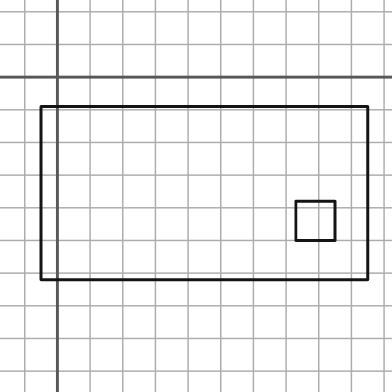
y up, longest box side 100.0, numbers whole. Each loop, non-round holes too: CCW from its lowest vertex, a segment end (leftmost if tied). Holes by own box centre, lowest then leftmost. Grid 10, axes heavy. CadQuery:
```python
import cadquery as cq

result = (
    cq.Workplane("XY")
    .moveTo(-5.0, -62.0)
    .lineTo(95.0, -62.0)
    .lineTo(95.0, -9.0)
    .lineTo(-5.0, -9.0)
    .close()
    .moveTo(73.0, -50.0)
    .lineTo(85.0, -50.0)
    .lineTo(85.0, -38.0)
    .lineTo(73.0, -38.0)
    .close()
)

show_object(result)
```